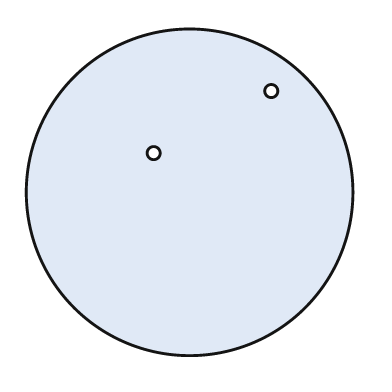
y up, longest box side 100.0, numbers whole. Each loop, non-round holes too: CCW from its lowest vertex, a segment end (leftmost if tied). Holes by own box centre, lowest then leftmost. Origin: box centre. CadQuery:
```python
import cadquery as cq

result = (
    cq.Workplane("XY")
    .moveTo(0.0, 0.0)
    .circle(50.0)
    .moveTo(-11.0, 12.0)
    .circle(2.0)
    .moveTo(25.0, 31.0)
    .circle(2.0)
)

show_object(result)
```